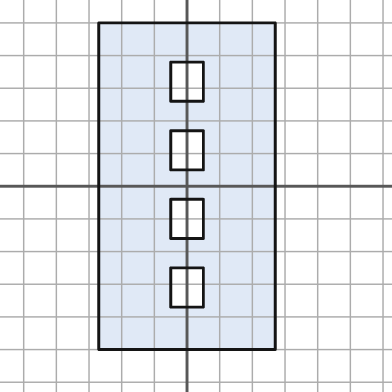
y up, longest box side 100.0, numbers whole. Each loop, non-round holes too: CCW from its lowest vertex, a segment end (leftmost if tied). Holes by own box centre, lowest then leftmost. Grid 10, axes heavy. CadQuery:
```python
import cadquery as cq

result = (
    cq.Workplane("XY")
    .moveTo(-27.0, -50.0)
    .lineTo(27.0, -50.0)
    .lineTo(27.0, 50.0)
    .lineTo(-27.0, 50.0)
    .close()
    .moveTo(-5.0, -37.0)
    .lineTo(5.0, -37.0)
    .lineTo(5.0, -25.0)
    .lineTo(-5.0, -25.0)
    .close()
    .moveTo(-5.0, -16.0)
    .lineTo(5.0, -16.0)
    .lineTo(5.0, -4.0)
    .lineTo(-5.0, -4.0)
    .close()
    .moveTo(-5.0, 5.0)
    .lineTo(5.0, 5.0)
    .lineTo(5.0, 17.0)
    .lineTo(-5.0, 17.0)
    .close()
    .moveTo(-5.0, 26.0)
    .lineTo(5.0, 26.0)
    .lineTo(5.0, 38.0)
    .lineTo(-5.0, 38.0)
    .close()
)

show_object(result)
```